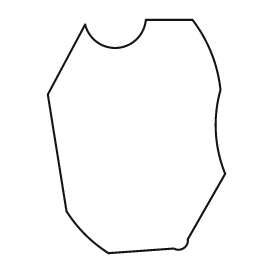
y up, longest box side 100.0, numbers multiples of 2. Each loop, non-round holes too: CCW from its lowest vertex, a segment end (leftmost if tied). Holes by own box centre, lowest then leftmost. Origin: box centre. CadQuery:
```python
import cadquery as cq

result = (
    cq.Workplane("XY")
    .moveTo(-12.0, -50.0)
    .lineTo(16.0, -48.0)
    .threePointArc((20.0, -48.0), (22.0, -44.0))
    .lineTo(38.0, -16.0)
    .threePointArc((34.0, 2.0), (36.0, 20.0))
    .threePointArc((32.0, 36.0), (24.0, 50.0))
    .lineTo(4.0, 50.0)
    .threePointArc((-8.0, 38.0), (-22.0, 48.0))
    .lineTo(-38.0, 18.0)
    .lineTo(-30.0, -32.0)
    .threePointArc((-22.0, -42.0), (-12.0, -50.0))
    .close()
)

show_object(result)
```